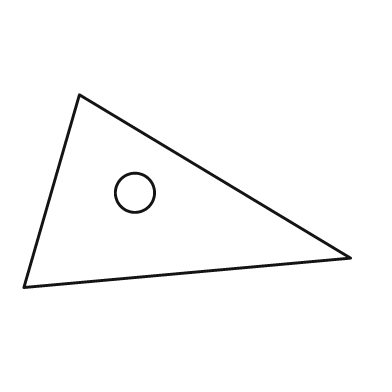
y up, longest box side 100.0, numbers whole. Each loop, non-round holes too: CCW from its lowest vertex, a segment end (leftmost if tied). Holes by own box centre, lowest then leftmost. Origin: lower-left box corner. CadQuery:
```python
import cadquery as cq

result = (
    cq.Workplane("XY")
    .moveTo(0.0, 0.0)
    .lineTo(100.0, 9.0)
    .lineTo(17.0, 59.0)
    .close()
    .moveTo(34.0, 29.0)
    .circle(6.0)
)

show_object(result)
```